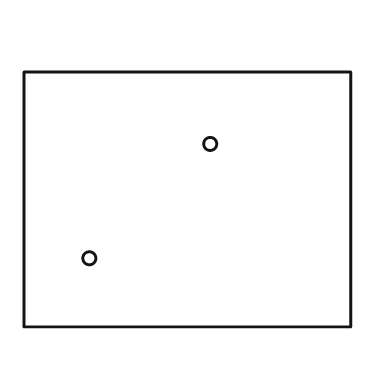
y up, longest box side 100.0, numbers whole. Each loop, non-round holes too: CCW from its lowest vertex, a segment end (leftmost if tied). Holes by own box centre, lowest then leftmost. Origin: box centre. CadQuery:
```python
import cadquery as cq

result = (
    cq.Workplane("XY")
    .moveTo(-50.0, -39.0)
    .lineTo(50.0, -39.0)
    .lineTo(50.0, 39.0)
    .lineTo(-50.0, 39.0)
    .close()
    .moveTo(-30.0, -18.0)
    .circle(2.0)
    .moveTo(7.0, 17.0)
    .circle(2.0)
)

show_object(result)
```